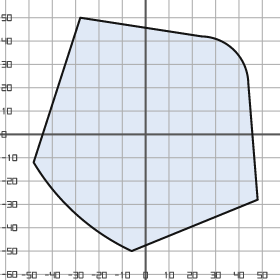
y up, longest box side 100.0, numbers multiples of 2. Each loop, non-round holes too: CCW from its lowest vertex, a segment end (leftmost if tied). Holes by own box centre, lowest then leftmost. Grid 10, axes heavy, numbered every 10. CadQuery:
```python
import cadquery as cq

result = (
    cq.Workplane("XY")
    .moveTo(-6.0, -50.0)
    .lineTo(48.0, -28.0)
    .lineTo(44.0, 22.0)
    .threePointArc((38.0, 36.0), (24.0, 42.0))
    .lineTo(-28.0, 50.0)
    .lineTo(-48.0, -12.0)
    .threePointArc((-30.0, -34.0), (-6.0, -50.0))
    .close()
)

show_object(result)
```